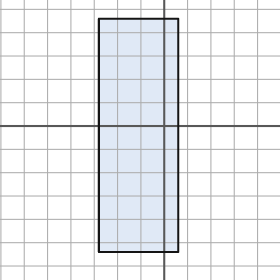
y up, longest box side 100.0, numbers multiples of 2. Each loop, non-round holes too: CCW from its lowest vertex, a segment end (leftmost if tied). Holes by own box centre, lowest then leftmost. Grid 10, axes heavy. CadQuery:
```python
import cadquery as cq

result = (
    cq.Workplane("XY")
    .moveTo(-28.0, -54.0)
    .lineTo(6.0, -54.0)
    .lineTo(6.0, 46.0)
    .lineTo(-28.0, 46.0)
    .close()
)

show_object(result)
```